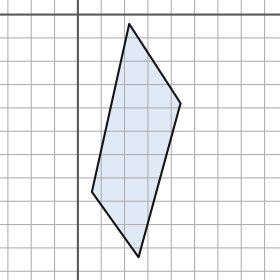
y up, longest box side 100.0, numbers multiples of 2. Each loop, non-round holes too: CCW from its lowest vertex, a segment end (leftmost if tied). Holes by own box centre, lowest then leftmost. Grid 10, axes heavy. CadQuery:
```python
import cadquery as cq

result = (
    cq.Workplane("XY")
    .moveTo(26.0, -104.0)
    .lineTo(44.0, -38.0)
    .lineTo(22.0, -4.0)
    .lineTo(6.0, -76.0)
    .close()
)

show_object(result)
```